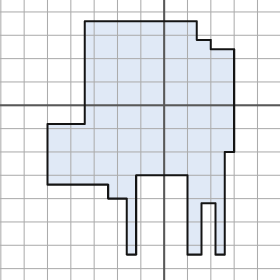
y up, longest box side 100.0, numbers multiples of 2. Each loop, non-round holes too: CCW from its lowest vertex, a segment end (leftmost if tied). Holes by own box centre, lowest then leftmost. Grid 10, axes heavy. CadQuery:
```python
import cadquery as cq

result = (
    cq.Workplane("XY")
    .moveTo(-16.0, -64.0)
    .lineTo(-12.0, -64.0)
    .lineTo(-12.0, -30.0)
    .lineTo(10.0, -30.0)
    .lineTo(10.0, -64.0)
    .lineTo(16.0, -64.0)
    .lineTo(16.0, -42.0)
    .lineTo(22.0, -42.0)
    .lineTo(22.0, -64.0)
    .lineTo(26.0, -64.0)
    .lineTo(26.0, -20.0)
    .lineTo(30.0, -20.0)
    .lineTo(30.0, 24.0)
    .lineTo(20.0, 24.0)
    .lineTo(20.0, 28.0)
    .lineTo(14.0, 28.0)
    .lineTo(14.0, 36.0)
    .lineTo(-34.0, 36.0)
    .lineTo(-34.0, -8.0)
    .lineTo(-50.0, -8.0)
    .lineTo(-50.0, -34.0)
    .lineTo(-24.0, -34.0)
    .lineTo(-24.0, -40.0)
    .lineTo(-16.0, -40.0)
    .close()
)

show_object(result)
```